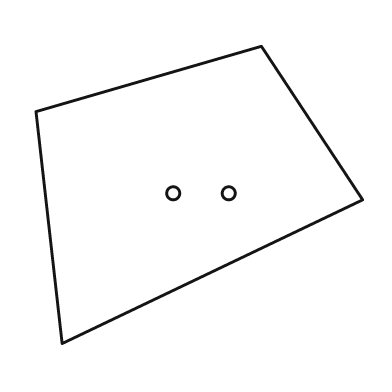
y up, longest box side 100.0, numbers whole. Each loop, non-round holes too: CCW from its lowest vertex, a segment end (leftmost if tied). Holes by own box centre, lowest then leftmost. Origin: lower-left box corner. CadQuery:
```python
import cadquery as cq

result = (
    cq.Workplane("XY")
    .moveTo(8.0, 0.0)
    .lineTo(100.0, 44.0)
    .lineTo(69.0, 91.0)
    .lineTo(0.0, 71.0)
    .close()
    .moveTo(42.0, 46.0)
    .circle(2.0)
    .moveTo(59.0, 46.0)
    .circle(2.0)
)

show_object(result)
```